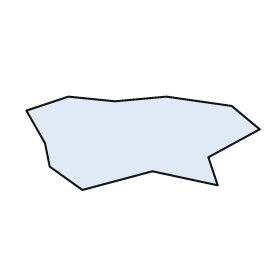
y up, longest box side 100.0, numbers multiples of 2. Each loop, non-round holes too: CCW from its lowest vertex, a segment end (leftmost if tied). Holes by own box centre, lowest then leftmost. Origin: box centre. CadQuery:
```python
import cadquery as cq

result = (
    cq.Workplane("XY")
    .moveTo(-26.0, -20.0)
    .lineTo(4.0, -12.0)
    .lineTo(32.0, -18.0)
    .lineTo(28.0, -6.0)
    .lineTo(50.0, 6.0)
    .lineTo(38.0, 16.0)
    .lineTo(10.0, 20.0)
    .lineTo(-12.0, 18.0)
    .lineTo(-32.0, 20.0)
    .lineTo(-50.0, 14.0)
    .lineTo(-42.0, 0.0)
    .lineTo(-40.0, -10.0)
    .close()
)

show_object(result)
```